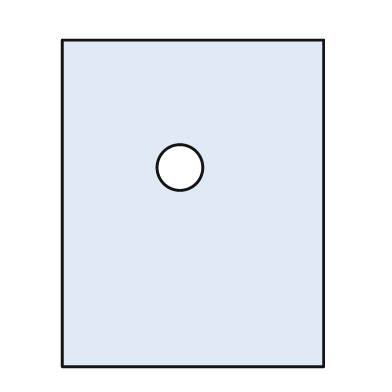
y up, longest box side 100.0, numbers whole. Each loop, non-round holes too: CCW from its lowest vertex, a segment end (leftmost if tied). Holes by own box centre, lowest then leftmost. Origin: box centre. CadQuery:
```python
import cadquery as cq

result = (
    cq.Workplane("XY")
    .moveTo(-40.0, -50.0)
    .lineTo(40.0, -50.0)
    .lineTo(40.0, 50.0)
    .lineTo(-40.0, 50.0)
    .close()
    .moveTo(-4.0, 11.0)
    .circle(7.0)
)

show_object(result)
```